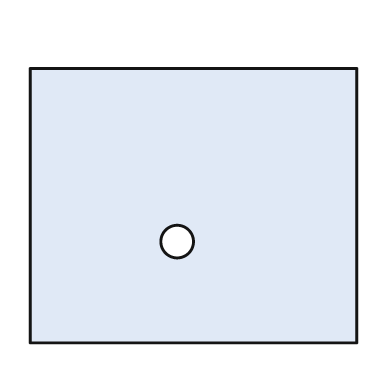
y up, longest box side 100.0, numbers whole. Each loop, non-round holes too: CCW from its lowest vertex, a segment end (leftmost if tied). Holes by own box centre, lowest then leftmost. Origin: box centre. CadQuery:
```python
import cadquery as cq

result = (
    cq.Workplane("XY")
    .moveTo(-50.0, -42.0)
    .lineTo(50.0, -42.0)
    .lineTo(50.0, 42.0)
    .lineTo(-50.0, 42.0)
    .close()
    .moveTo(-5.0, -11.0)
    .circle(5.0)
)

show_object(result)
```